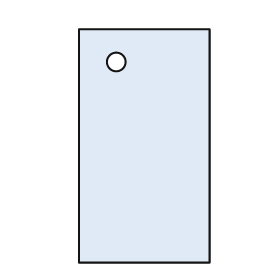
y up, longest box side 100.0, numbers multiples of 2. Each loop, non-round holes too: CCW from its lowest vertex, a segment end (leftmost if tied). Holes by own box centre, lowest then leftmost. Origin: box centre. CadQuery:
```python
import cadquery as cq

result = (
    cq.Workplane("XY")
    .moveTo(-28.0, -50.0)
    .lineTo(28.0, -50.0)
    .lineTo(28.0, 50.0)
    .lineTo(-28.0, 50.0)
    .close()
    .moveTo(-12.0, 36.0)
    .circle(4.0)
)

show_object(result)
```